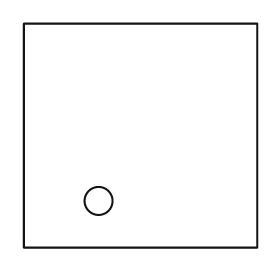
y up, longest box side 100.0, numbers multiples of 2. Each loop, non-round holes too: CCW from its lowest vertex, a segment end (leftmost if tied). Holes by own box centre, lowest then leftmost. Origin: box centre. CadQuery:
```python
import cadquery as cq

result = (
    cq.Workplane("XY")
    .moveTo(-50.0, -48.0)
    .lineTo(50.0, -48.0)
    .lineTo(50.0, 48.0)
    .lineTo(-50.0, 48.0)
    .close()
    .moveTo(-18.0, -28.0)
    .circle(6.0)
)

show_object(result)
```